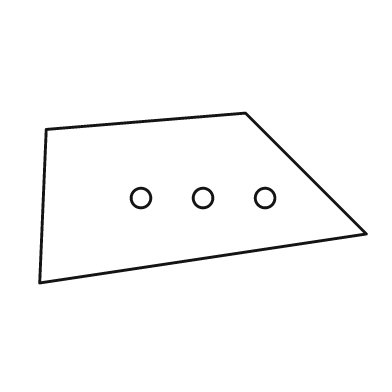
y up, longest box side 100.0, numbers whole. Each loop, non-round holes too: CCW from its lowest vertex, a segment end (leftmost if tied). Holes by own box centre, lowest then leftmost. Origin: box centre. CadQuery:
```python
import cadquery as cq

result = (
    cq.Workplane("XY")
    .moveTo(-50.0, -26.0)
    .lineTo(50.0, -11.0)
    .lineTo(13.0, 26.0)
    .lineTo(-48.0, 21.0)
    .close()
    .moveTo(-19.0, 0.0)
    .circle(3.0)
    .moveTo(0.0, 0.0)
    .circle(3.0)
    .moveTo(19.0, 0.0)
    .circle(3.0)
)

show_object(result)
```